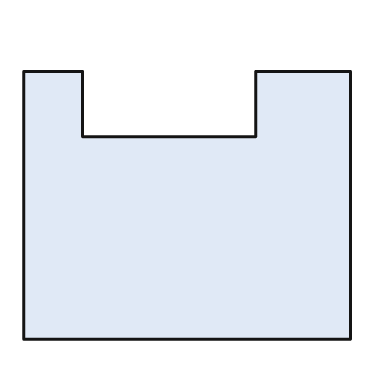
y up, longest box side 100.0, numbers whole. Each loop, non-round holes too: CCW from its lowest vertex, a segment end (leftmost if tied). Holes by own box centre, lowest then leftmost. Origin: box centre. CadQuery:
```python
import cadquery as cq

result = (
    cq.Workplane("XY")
    .moveTo(-50.0, -41.0)
    .lineTo(50.0, -41.0)
    .lineTo(50.0, 41.0)
    .lineTo(21.0, 41.0)
    .lineTo(21.0, 21.0)
    .lineTo(-32.0, 21.0)
    .lineTo(-32.0, 41.0)
    .lineTo(-50.0, 41.0)
    .close()
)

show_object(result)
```